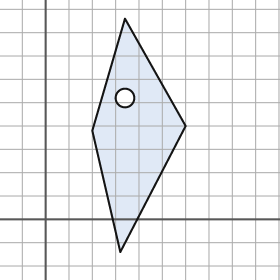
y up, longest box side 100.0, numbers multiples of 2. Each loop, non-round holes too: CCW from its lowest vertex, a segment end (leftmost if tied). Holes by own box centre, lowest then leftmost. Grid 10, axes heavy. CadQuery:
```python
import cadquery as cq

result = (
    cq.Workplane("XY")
    .moveTo(32.0, -14.0)
    .lineTo(60.0, 40.0)
    .lineTo(34.0, 86.0)
    .lineTo(20.0, 38.0)
    .close()
    .moveTo(34.0, 52.0)
    .circle(4.0)
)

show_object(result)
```